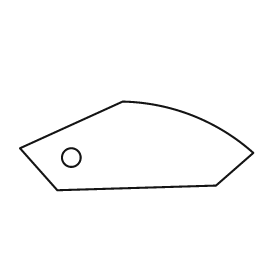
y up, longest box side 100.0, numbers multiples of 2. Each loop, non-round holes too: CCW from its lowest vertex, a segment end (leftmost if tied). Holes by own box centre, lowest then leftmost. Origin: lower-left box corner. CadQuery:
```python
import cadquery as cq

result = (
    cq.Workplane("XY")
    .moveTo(16.0, 0.0)
    .lineTo(84.0, 2.0)
    .lineTo(100.0, 16.0)
    .threePointArc((74.0, 32.0), (44.0, 38.0))
    .lineTo(0.0, 18.0)
    .close()
    .moveTo(22.0, 14.0)
    .circle(4.0)
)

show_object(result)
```